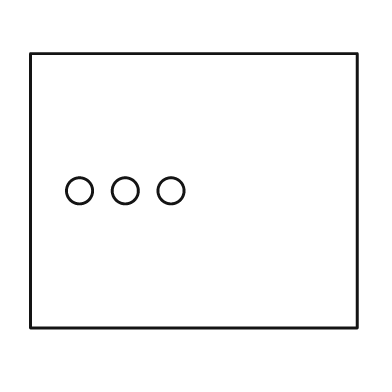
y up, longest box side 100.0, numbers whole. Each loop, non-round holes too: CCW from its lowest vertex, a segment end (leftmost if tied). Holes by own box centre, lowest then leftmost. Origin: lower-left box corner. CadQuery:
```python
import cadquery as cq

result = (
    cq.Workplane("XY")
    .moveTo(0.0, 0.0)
    .lineTo(100.0, 0.0)
    .lineTo(100.0, 84.0)
    .lineTo(0.0, 84.0)
    .close()
    .moveTo(15.0, 42.0)
    .circle(4.0)
    .moveTo(29.0, 42.0)
    .circle(4.0)
    .moveTo(43.0, 42.0)
    .circle(4.0)
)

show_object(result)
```